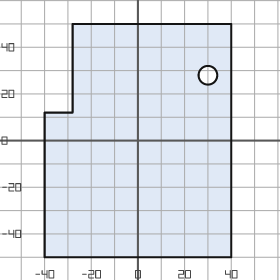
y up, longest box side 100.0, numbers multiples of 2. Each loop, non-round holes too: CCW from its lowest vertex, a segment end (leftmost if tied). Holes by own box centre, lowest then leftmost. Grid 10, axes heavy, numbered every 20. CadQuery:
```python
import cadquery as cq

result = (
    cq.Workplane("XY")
    .moveTo(-40.0, -50.0)
    .lineTo(40.0, -50.0)
    .lineTo(40.0, 50.0)
    .lineTo(-28.0, 50.0)
    .lineTo(-28.0, 12.0)
    .lineTo(-40.0, 12.0)
    .close()
    .moveTo(30.0, 28.0)
    .circle(4.0)
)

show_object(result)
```